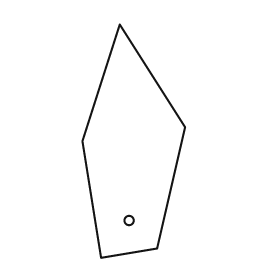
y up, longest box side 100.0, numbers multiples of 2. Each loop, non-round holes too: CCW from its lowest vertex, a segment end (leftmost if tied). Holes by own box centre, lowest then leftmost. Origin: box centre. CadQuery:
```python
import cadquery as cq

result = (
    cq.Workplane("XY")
    .moveTo(-14.0, -50.0)
    .lineTo(10.0, -46.0)
    .lineTo(22.0, 6.0)
    .lineTo(-6.0, 50.0)
    .lineTo(-22.0, 0.0)
    .close()
    .moveTo(-2.0, -34.0)
    .circle(2.0)
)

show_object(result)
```